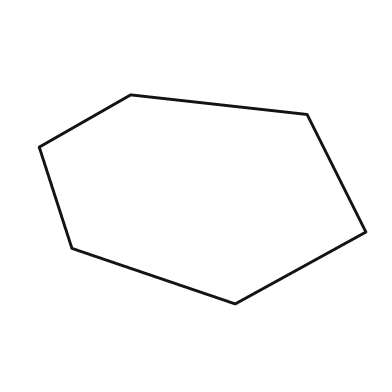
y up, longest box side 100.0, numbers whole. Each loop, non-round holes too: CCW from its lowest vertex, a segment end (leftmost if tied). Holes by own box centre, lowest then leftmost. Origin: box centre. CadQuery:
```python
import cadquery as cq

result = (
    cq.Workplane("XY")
    .moveTo(10.0, -32.0)
    .lineTo(50.0, -10.0)
    .lineTo(32.0, 26.0)
    .lineTo(-22.0, 32.0)
    .lineTo(-50.0, 16.0)
    .lineTo(-40.0, -15.0)
    .close()
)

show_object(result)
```